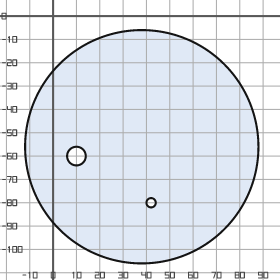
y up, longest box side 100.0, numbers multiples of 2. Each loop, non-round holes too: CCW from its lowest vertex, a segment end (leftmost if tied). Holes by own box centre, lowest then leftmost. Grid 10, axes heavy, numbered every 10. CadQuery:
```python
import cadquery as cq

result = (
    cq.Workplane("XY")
    .moveTo(38.0, -56.0)
    .circle(50.0)
    .moveTo(42.0, -80.0)
    .circle(2.0)
    .moveTo(10.0, -60.0)
    .circle(4.0)
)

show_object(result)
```